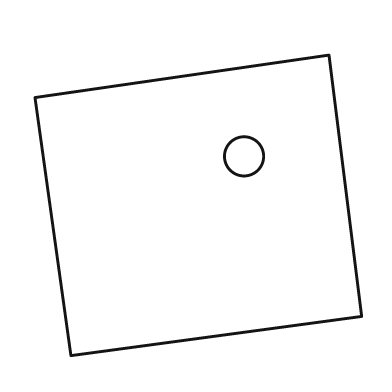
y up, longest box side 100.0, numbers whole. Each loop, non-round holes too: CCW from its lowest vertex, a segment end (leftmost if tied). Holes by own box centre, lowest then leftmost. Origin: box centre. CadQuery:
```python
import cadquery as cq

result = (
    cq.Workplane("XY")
    .moveTo(-39.0, -46.0)
    .lineTo(50.0, -34.0)
    .lineTo(40.0, 46.0)
    .lineTo(-50.0, 33.0)
    .close()
    .moveTo(14.0, 15.0)
    .circle(6.0)
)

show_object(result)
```